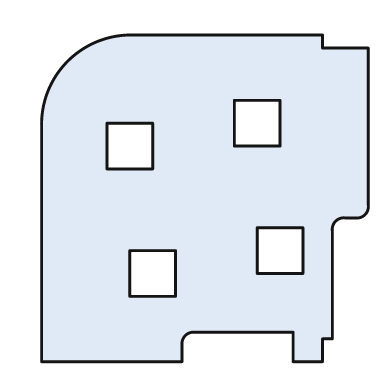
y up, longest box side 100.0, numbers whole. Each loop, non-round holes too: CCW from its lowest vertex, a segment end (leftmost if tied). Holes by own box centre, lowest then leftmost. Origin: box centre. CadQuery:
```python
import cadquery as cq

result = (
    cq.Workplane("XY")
    .moveTo(-50.0, -50.0)
    .lineTo(-7.0, -50.0)
    .lineTo(-7.0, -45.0)
    .threePointArc((-6.0, -42.0), (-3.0, -41.0))
    .lineTo(27.0, -41.0)
    .lineTo(27.0, -50.0)
    .lineTo(36.0, -50.0)
    .lineTo(36.0, -43.0)
    .lineTo(39.0, -43.0)
    .lineTo(39.0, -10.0)
    .threePointArc((40.0, -7.0), (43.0, -6.0))
    .lineTo(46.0, -6.0)
    .threePointArc((49.0, -5.0), (50.0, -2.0))
    .lineTo(50.0, 46.0)
    .lineTo(36.0, 46.0)
    .lineTo(36.0, 50.0)
    .lineTo(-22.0, 50.0)
    .threePointArc((-42.0, 42.0), (-50.0, 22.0))
    .close()
    .moveTo(-23.0, -30.0)
    .lineTo(-9.0, -30.0)
    .lineTo(-9.0, -16.0)
    .lineTo(-23.0, -16.0)
    .close()
    .moveTo(16.0, -23.0)
    .lineTo(30.0, -23.0)
    .lineTo(30.0, -9.0)
    .lineTo(16.0, -9.0)
    .close()
    .moveTo(-30.0, 9.0)
    .lineTo(-16.0, 9.0)
    .lineTo(-16.0, 23.0)
    .lineTo(-30.0, 23.0)
    .close()
    .moveTo(9.0, 16.0)
    .lineTo(23.0, 16.0)
    .lineTo(23.0, 30.0)
    .lineTo(9.0, 30.0)
    .close()
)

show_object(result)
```